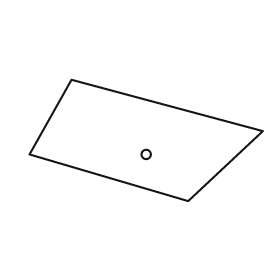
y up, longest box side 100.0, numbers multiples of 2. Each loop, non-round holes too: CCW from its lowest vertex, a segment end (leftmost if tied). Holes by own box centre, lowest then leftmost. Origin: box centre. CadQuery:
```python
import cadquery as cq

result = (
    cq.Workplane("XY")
    .moveTo(18.0, -26.0)
    .lineTo(50.0, 4.0)
    .lineTo(-32.0, 26.0)
    .lineTo(-50.0, -6.0)
    .close()
    .moveTo(0.0, -6.0)
    .circle(2.0)
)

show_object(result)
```